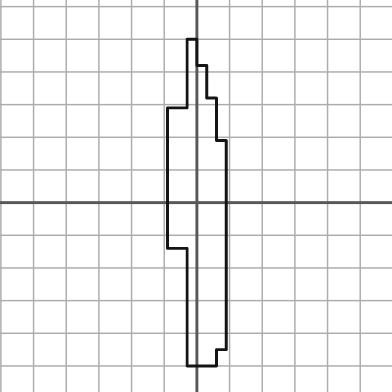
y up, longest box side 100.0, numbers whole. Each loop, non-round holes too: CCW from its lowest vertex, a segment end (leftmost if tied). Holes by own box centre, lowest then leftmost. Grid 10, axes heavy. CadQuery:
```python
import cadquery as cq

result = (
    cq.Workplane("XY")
    .moveTo(-3.0, -50.0)
    .lineTo(6.0, -50.0)
    .lineTo(6.0, -45.0)
    .lineTo(9.0, -45.0)
    .lineTo(9.0, 19.0)
    .lineTo(6.0, 19.0)
    .lineTo(6.0, 32.0)
    .lineTo(3.0, 32.0)
    .lineTo(3.0, 42.0)
    .lineTo(0.0, 42.0)
    .lineTo(0.0, 50.0)
    .lineTo(-3.0, 50.0)
    .lineTo(-3.0, 29.0)
    .lineTo(-9.0, 29.0)
    .lineTo(-9.0, -14.0)
    .lineTo(-3.0, -14.0)
    .close()
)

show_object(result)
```